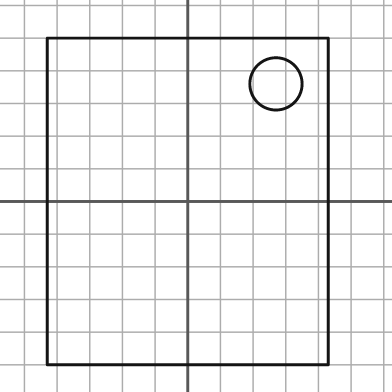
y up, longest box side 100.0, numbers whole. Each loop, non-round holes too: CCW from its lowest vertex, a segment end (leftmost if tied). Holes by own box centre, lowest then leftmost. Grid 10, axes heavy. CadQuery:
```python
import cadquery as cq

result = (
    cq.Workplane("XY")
    .moveTo(-43.0, -50.0)
    .lineTo(43.0, -50.0)
    .lineTo(43.0, 50.0)
    .lineTo(-43.0, 50.0)
    .close()
    .moveTo(27.0, 36.0)
    .circle(8.0)
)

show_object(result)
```